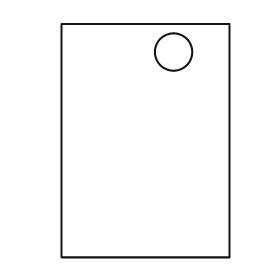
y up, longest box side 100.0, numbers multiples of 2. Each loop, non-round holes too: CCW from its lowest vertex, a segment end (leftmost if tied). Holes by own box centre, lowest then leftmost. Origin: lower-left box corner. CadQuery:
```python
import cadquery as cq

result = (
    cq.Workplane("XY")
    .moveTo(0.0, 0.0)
    .lineTo(72.0, 0.0)
    .lineTo(72.0, 100.0)
    .lineTo(0.0, 100.0)
    .close()
    .moveTo(48.0, 88.0)
    .circle(8.0)
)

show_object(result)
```